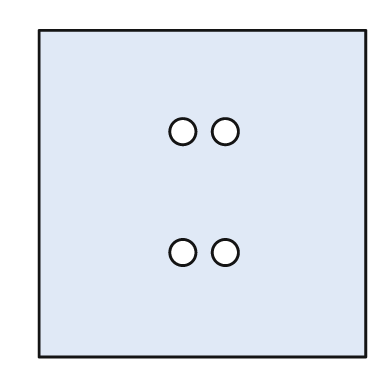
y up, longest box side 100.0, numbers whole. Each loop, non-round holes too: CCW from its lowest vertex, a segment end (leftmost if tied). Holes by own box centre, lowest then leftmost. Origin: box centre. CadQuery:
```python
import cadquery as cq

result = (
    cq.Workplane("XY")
    .moveTo(-50.0, -50.0)
    .lineTo(50.0, -50.0)
    .lineTo(50.0, 50.0)
    .lineTo(-50.0, 50.0)
    .close()
    .moveTo(-6.0, -18.0)
    .circle(4.0)
    .moveTo(7.0, -18.0)
    .circle(4.0)
    .moveTo(-6.0, 19.0)
    .circle(4.0)
    .moveTo(7.0, 19.0)
    .circle(4.0)
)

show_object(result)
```